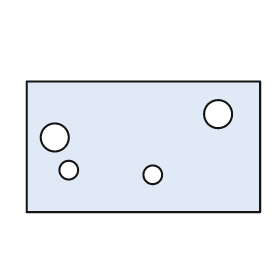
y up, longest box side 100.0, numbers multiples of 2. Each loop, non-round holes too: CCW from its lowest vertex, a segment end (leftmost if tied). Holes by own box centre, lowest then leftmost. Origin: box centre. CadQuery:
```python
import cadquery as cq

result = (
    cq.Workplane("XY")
    .moveTo(-50.0, -28.0)
    .lineTo(50.0, -28.0)
    .lineTo(50.0, 28.0)
    .lineTo(-50.0, 28.0)
    .close()
    .moveTo(4.0, -12.0)
    .circle(4.0)
    .moveTo(-32.0, -10.0)
    .circle(4.0)
    .moveTo(-38.0, 4.0)
    .circle(6.0)
    .moveTo(32.0, 14.0)
    .circle(6.0)
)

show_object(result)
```